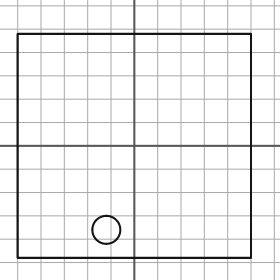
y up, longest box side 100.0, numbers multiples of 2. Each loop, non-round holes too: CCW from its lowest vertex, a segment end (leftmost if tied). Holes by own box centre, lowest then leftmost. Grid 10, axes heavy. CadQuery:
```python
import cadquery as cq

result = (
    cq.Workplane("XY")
    .moveTo(-50.0, -48.0)
    .lineTo(50.0, -48.0)
    .lineTo(50.0, 48.0)
    .lineTo(-50.0, 48.0)
    .close()
    .moveTo(-12.0, -36.0)
    .circle(6.0)
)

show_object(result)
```